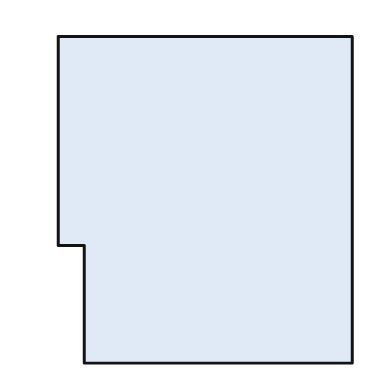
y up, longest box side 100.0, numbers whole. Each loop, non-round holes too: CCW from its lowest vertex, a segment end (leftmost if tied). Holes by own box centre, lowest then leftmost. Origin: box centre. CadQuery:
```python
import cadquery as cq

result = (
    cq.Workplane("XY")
    .moveTo(-37.0, -50.0)
    .lineTo(45.0, -50.0)
    .lineTo(45.0, 50.0)
    .lineTo(-45.0, 50.0)
    .lineTo(-45.0, -14.0)
    .lineTo(-37.0, -14.0)
    .close()
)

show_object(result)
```